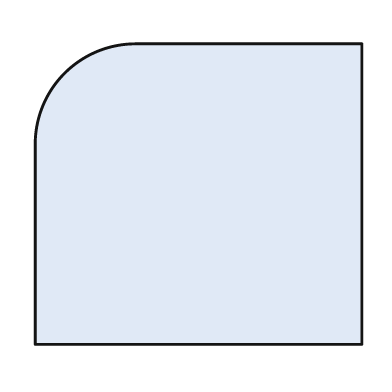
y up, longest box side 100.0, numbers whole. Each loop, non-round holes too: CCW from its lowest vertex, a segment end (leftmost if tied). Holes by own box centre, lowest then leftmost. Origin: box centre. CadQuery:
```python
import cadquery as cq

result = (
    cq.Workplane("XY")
    .moveTo(-50.0, -46.0)
    .lineTo(50.0, -46.0)
    .lineTo(50.0, 46.0)
    .lineTo(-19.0, 46.0)
    .threePointArc((-41.0, 37.0), (-50.0, 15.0))
    .close()
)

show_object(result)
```